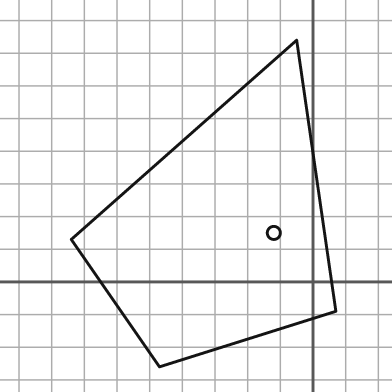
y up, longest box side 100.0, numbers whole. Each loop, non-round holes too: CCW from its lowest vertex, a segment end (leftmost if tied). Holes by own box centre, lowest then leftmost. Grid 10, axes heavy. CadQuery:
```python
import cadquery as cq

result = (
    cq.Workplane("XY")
    .moveTo(-47.0, -26.0)
    .lineTo(7.0, -9.0)
    .lineTo(-5.0, 74.0)
    .lineTo(-74.0, 13.0)
    .close()
    .moveTo(-12.0, 15.0)
    .circle(2.0)
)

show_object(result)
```